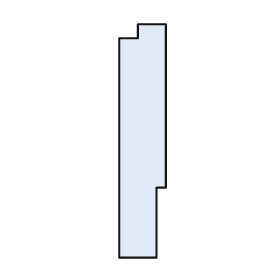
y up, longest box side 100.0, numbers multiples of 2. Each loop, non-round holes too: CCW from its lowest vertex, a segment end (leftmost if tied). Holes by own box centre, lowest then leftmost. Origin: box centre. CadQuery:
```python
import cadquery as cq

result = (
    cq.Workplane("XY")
    .moveTo(-10.0, -50.0)
    .lineTo(6.0, -50.0)
    .lineTo(6.0, -20.0)
    .lineTo(10.0, -20.0)
    .lineTo(10.0, 50.0)
    .lineTo(-2.0, 50.0)
    .lineTo(-2.0, 44.0)
    .lineTo(-10.0, 44.0)
    .close()
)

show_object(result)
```